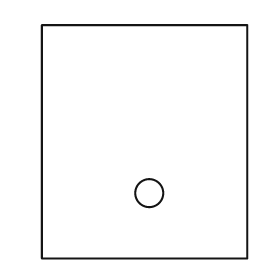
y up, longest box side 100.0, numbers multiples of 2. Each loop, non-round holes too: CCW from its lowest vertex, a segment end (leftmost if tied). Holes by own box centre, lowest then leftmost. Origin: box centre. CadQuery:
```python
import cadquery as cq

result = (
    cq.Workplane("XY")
    .moveTo(-44.0, -50.0)
    .lineTo(44.0, -50.0)
    .lineTo(44.0, 50.0)
    .lineTo(-44.0, 50.0)
    .close()
    .moveTo(2.0, -22.0)
    .circle(6.0)
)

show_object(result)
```